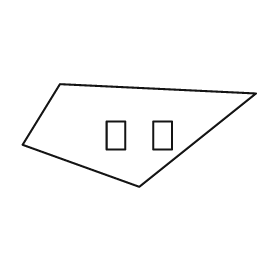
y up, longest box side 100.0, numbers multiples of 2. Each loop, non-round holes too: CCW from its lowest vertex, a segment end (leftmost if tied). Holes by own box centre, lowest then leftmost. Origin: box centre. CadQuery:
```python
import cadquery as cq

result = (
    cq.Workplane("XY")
    .moveTo(0.0, -22.0)
    .lineTo(50.0, 18.0)
    .lineTo(-34.0, 22.0)
    .lineTo(-50.0, -4.0)
    .close()
    .moveTo(-14.0, -6.0)
    .lineTo(-6.0, -6.0)
    .lineTo(-6.0, 6.0)
    .lineTo(-14.0, 6.0)
    .close()
    .moveTo(6.0, -6.0)
    .lineTo(14.0, -6.0)
    .lineTo(14.0, 6.0)
    .lineTo(6.0, 6.0)
    .close()
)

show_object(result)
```